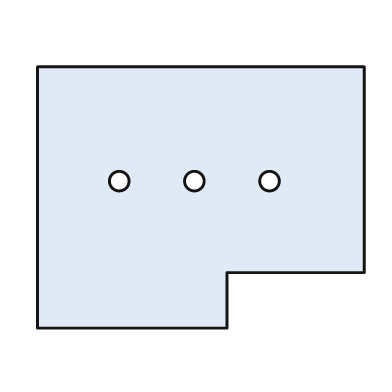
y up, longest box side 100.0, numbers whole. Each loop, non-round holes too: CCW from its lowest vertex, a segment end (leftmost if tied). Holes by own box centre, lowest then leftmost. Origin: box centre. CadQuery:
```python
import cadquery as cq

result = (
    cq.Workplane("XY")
    .moveTo(-50.0, -40.0)
    .lineTo(8.0, -40.0)
    .lineTo(8.0, -23.0)
    .lineTo(50.0, -23.0)
    .lineTo(50.0, 40.0)
    .lineTo(-50.0, 40.0)
    .close()
    .moveTo(-25.0, 5.0)
    .circle(3.0)
    .moveTo(-2.0, 5.0)
    .circle(3.0)
    .moveTo(21.0, 5.0)
    .circle(3.0)
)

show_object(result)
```